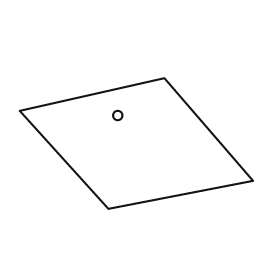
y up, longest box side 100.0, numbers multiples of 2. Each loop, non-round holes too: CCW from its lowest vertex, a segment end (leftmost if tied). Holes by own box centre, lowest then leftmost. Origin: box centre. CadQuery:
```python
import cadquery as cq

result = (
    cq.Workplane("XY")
    .moveTo(-12.0, -28.0)
    .lineTo(50.0, -16.0)
    .lineTo(12.0, 28.0)
    .lineTo(-50.0, 14.0)
    .close()
    .moveTo(-8.0, 12.0)
    .circle(2.0)
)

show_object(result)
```